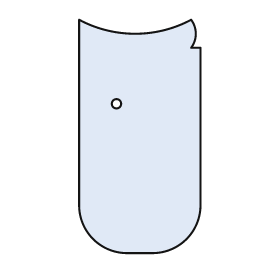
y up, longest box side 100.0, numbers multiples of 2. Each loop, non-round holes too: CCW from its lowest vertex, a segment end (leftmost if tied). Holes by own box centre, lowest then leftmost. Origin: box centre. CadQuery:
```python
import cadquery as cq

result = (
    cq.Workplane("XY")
    .moveTo(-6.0, -50.0)
    .lineTo(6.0, -50.0)
    .threePointArc((20.0, -44.0), (26.0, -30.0))
    .lineTo(26.0, 38.0)
    .lineTo(22.0, 38.0)
    .threePointArc((24.0, 44.0), (22.0, 50.0))
    .threePointArc((-2.0, 44.0), (-26.0, 50.0))
    .lineTo(-26.0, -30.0)
    .threePointArc((-20.0, -44.0), (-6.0, -50.0))
    .close()
    .moveTo(-10.0, 14.0)
    .circle(2.0)
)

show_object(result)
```